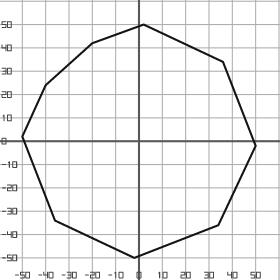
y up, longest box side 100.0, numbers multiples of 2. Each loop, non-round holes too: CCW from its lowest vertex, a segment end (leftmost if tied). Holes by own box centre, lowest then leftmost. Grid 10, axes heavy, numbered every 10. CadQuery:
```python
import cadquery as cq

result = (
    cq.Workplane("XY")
    .moveTo(-2.0, -50.0)
    .lineTo(34.0, -36.0)
    .lineTo(50.0, -2.0)
    .lineTo(36.0, 34.0)
    .lineTo(2.0, 50.0)
    .lineTo(-20.0, 42.0)
    .lineTo(-40.0, 24.0)
    .lineTo(-50.0, 2.0)
    .lineTo(-36.0, -34.0)
    .close()
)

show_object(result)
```